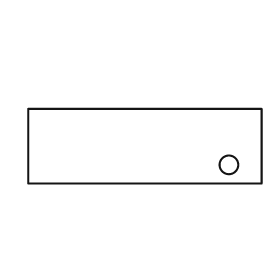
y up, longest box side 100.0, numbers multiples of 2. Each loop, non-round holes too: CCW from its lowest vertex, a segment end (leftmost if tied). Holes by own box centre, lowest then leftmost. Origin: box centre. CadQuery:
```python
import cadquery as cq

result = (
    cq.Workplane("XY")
    .moveTo(-50.0, -16.0)
    .lineTo(50.0, -16.0)
    .lineTo(50.0, 16.0)
    .lineTo(-50.0, 16.0)
    .close()
    .moveTo(36.0, -8.0)
    .circle(4.0)
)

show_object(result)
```